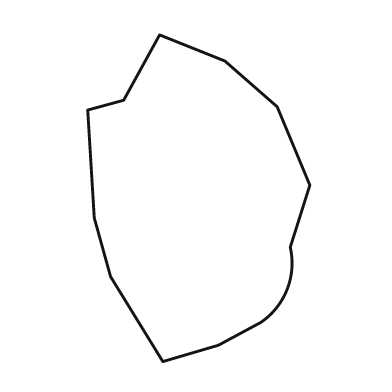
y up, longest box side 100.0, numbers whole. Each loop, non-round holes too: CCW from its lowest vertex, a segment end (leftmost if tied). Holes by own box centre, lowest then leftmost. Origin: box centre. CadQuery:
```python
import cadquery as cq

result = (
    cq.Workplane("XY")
    .moveTo(-11.0, -50.0)
    .lineTo(6.0, -45.0)
    .lineTo(19.0, -38.0)
    .threePointArc((27.0, -28.0), (28.0, -15.0))
    .lineTo(34.0, 4.0)
    .lineTo(24.0, 28.0)
    .lineTo(8.0, 42.0)
    .lineTo(-12.0, 50.0)
    .lineTo(-23.0, 30.0)
    .lineTo(-34.0, 27.0)
    .lineTo(-32.0, -6.0)
    .lineTo(-27.0, -24.0)
    .close()
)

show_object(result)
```